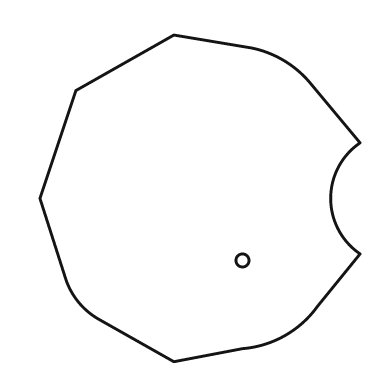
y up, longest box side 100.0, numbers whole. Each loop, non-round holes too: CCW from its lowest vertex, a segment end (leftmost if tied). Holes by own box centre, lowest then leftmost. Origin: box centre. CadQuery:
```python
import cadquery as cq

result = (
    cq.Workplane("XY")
    .moveTo(-8.0, -50.0)
    .lineTo(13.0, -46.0)
    .threePointArc((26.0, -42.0), (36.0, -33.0))
    .lineTo(49.0, -17.0)
    .threePointArc((40.0, 0.0), (49.0, 17.0))
    .lineTo(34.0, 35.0)
    .threePointArc((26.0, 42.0), (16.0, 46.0))
    .lineTo(-8.0, 50.0)
    .lineTo(-38.0, 33.0)
    .lineTo(-49.0, 0.0)
    .lineTo(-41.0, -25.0)
    .threePointArc((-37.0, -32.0), (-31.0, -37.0))
    .close()
    .moveTo(13.0, -19.0)
    .circle(2.0)
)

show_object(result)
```